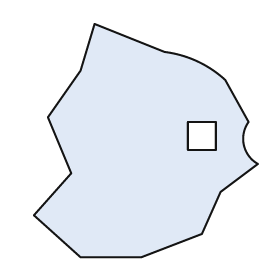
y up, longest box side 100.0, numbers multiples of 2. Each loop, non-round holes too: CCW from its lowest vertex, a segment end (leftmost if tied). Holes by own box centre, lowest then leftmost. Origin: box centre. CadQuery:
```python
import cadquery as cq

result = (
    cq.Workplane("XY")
    .moveTo(-28.0, -50.0)
    .lineTo(-2.0, -50.0)
    .lineTo(24.0, -40.0)
    .lineTo(32.0, -22.0)
    .lineTo(48.0, -10.0)
    .threePointArc((42.0, -2.0), (44.0, 8.0))
    .lineTo(34.0, 26.0)
    .threePointArc((22.0, 34.0), (8.0, 38.0))
    .lineTo(-22.0, 50.0)
    .lineTo(-28.0, 30.0)
    .lineTo(-42.0, 10.0)
    .lineTo(-32.0, -14.0)
    .lineTo(-48.0, -32.0)
    .close()
    .moveTo(18.0, -4.0)
    .lineTo(30.0, -4.0)
    .lineTo(30.0, 8.0)
    .lineTo(18.0, 8.0)
    .close()
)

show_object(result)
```